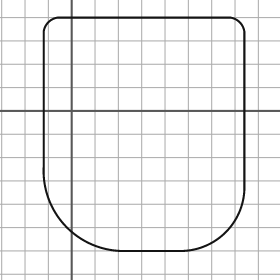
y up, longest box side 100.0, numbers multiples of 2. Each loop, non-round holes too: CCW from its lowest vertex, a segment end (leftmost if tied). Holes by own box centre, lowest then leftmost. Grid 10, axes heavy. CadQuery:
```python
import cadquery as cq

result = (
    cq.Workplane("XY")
    .moveTo(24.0, -60.0)
    .lineTo(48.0, -60.0)
    .threePointArc((66.0, -52.0), (74.0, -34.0))
    .lineTo(74.0, 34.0)
    .threePointArc((72.0, 38.0), (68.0, 40.0))
    .lineTo(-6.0, 40.0)
    .threePointArc((-10.0, 38.0), (-12.0, 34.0))
    .lineTo(-12.0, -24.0)
    .threePointArc((-2.0, -50.0), (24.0, -60.0))
    .close()
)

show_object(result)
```